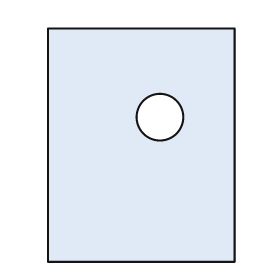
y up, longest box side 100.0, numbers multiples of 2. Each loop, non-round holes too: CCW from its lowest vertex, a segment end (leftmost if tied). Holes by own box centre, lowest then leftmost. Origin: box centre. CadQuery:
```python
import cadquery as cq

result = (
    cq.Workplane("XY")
    .moveTo(-40.0, -50.0)
    .lineTo(40.0, -50.0)
    .lineTo(40.0, 50.0)
    .lineTo(-40.0, 50.0)
    .close()
    .moveTo(8.0, 12.0)
    .circle(10.0)
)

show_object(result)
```